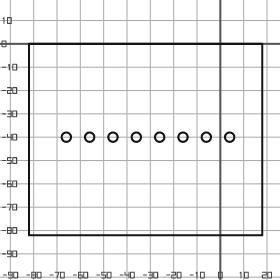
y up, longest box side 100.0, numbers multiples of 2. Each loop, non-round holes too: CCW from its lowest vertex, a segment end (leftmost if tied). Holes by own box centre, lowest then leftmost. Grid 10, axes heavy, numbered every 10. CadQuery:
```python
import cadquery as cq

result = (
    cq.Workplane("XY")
    .moveTo(-82.0, -82.0)
    .lineTo(18.0, -82.0)
    .lineTo(18.0, 0.0)
    .lineTo(-82.0, 0.0)
    .close()
    .moveTo(-66.0, -40.0)
    .circle(2.0)
    .moveTo(-56.0, -40.0)
    .circle(2.0)
    .moveTo(-46.0, -40.0)
    .circle(2.0)
    .moveTo(-36.0, -40.0)
    .circle(2.0)
    .moveTo(-26.0, -40.0)
    .circle(2.0)
    .moveTo(-16.0, -40.0)
    .circle(2.0)
    .moveTo(-6.0, -40.0)
    .circle(2.0)
    .moveTo(4.0, -40.0)
    .circle(2.0)
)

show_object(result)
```